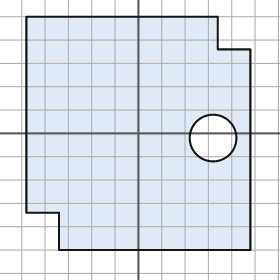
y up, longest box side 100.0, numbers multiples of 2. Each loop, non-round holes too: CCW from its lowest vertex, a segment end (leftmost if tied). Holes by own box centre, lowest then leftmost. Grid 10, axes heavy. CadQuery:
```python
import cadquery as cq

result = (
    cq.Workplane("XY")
    .moveTo(-34.0, -50.0)
    .lineTo(48.0, -50.0)
    .lineTo(48.0, 36.0)
    .lineTo(34.0, 36.0)
    .lineTo(34.0, 50.0)
    .lineTo(-48.0, 50.0)
    .lineTo(-48.0, -34.0)
    .lineTo(-34.0, -34.0)
    .close()
    .moveTo(32.0, -2.0)
    .circle(10.0)
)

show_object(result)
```